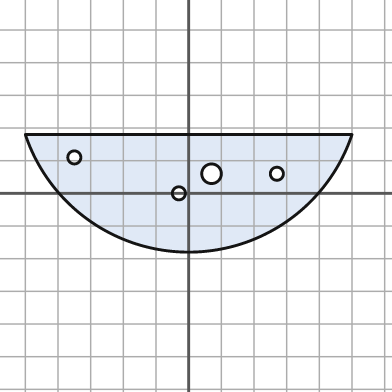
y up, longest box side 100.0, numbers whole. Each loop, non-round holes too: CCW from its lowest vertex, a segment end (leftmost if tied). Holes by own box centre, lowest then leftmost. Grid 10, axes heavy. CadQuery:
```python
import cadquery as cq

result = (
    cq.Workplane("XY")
    .moveTo(-50.0, 18.0)
    .threePointArc((0.0, -18.0), (50.0, 18.0))
    .close()
    .moveTo(-3.0, 0.0)
    .circle(2.0)
    .moveTo(7.0, 6.0)
    .circle(3.0)
    .moveTo(27.0, 6.0)
    .circle(2.0)
    .moveTo(-35.0, 11.0)
    .circle(2.0)
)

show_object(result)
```